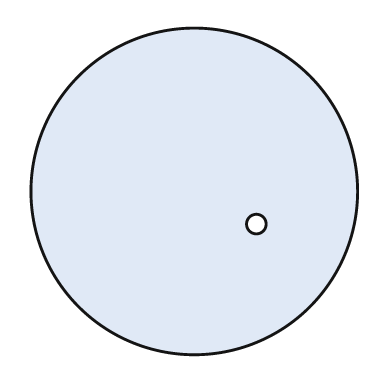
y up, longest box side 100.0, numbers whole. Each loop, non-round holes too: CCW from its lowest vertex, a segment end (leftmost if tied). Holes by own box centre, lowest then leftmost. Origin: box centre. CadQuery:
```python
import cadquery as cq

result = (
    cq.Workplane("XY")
    .moveTo(0.0, 0.0)
    .circle(50.0)
    .moveTo(19.0, -10.0)
    .circle(3.0)
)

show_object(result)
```